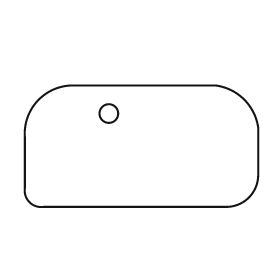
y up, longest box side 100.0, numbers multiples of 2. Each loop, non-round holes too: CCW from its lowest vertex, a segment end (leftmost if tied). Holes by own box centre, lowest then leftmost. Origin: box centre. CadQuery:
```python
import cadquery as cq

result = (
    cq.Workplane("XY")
    .moveTo(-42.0, -26.0)
    .lineTo(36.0, -26.0)
    .threePointArc((46.0, -22.0), (50.0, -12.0))
    .lineTo(50.0, 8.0)
    .threePointArc((44.0, 20.0), (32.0, 26.0))
    .lineTo(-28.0, 26.0)
    .threePointArc((-44.0, 20.0), (-50.0, 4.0))
    .lineTo(-50.0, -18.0)
    .threePointArc((-48.0, -24.0), (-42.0, -26.0))
    .close()
    .moveTo(-14.0, 14.0)
    .circle(4.0)
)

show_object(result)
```